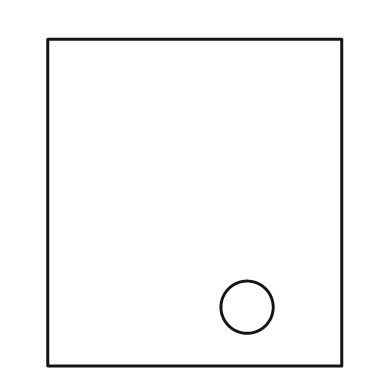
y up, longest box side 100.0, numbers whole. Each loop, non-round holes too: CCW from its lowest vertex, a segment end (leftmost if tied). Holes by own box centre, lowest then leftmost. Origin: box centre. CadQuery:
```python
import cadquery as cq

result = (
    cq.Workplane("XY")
    .moveTo(-45.0, -50.0)
    .lineTo(45.0, -50.0)
    .lineTo(45.0, 50.0)
    .lineTo(-45.0, 50.0)
    .close()
    .moveTo(16.0, -32.0)
    .circle(8.0)
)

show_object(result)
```